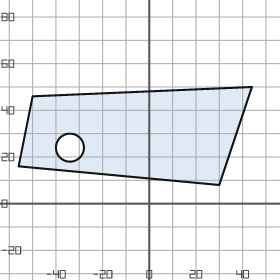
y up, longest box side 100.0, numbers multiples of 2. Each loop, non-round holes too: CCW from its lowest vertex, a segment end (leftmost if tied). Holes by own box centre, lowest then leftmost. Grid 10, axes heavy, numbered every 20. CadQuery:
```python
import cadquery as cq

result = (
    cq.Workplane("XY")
    .moveTo(30.0, 8.0)
    .lineTo(44.0, 50.0)
    .lineTo(-50.0, 46.0)
    .lineTo(-56.0, 16.0)
    .close()
    .moveTo(-34.0, 24.0)
    .circle(6.0)
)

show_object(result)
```